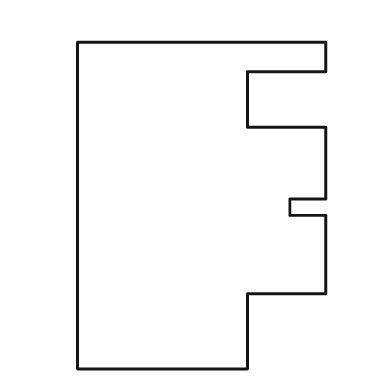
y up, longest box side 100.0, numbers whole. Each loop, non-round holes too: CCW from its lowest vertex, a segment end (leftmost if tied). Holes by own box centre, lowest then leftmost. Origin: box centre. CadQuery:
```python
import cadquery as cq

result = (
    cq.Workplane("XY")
    .moveTo(-38.0, -50.0)
    .lineTo(14.0, -50.0)
    .lineTo(14.0, -27.0)
    .lineTo(38.0, -27.0)
    .lineTo(38.0, -3.0)
    .lineTo(27.0, -3.0)
    .lineTo(27.0, 2.0)
    .lineTo(38.0, 2.0)
    .lineTo(38.0, 24.0)
    .lineTo(14.0, 24.0)
    .lineTo(14.0, 41.0)
    .lineTo(38.0, 41.0)
    .lineTo(38.0, 50.0)
    .lineTo(-38.0, 50.0)
    .close()
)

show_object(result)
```